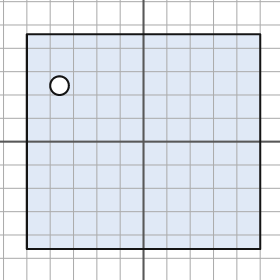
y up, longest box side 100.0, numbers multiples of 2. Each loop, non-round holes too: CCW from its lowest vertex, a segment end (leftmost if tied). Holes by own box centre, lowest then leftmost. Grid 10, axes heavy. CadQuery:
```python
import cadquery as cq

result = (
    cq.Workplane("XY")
    .moveTo(-50.0, -46.0)
    .lineTo(50.0, -46.0)
    .lineTo(50.0, 46.0)
    .lineTo(-50.0, 46.0)
    .close()
    .moveTo(-36.0, 24.0)
    .circle(4.0)
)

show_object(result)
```